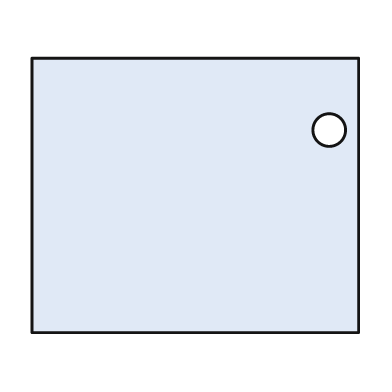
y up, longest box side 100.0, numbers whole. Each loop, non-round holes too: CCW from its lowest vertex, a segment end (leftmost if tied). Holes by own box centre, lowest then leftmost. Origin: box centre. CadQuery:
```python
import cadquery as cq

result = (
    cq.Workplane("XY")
    .moveTo(-50.0, -42.0)
    .lineTo(50.0, -42.0)
    .lineTo(50.0, 42.0)
    .lineTo(-50.0, 42.0)
    .close()
    .moveTo(41.0, 20.0)
    .circle(5.0)
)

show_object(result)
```